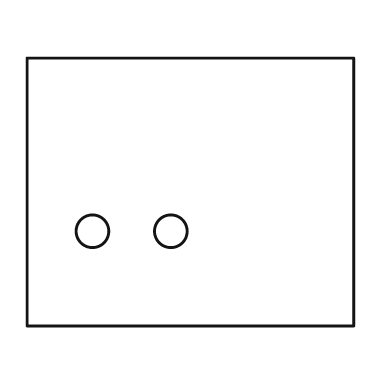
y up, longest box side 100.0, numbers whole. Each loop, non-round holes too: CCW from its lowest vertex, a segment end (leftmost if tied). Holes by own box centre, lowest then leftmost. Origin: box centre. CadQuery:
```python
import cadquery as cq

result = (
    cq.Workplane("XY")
    .moveTo(-50.0, -41.0)
    .lineTo(50.0, -41.0)
    .lineTo(50.0, 41.0)
    .lineTo(-50.0, 41.0)
    .close()
    .moveTo(-30.0, -12.0)
    .circle(5.0)
    .moveTo(-6.0, -12.0)
    .circle(5.0)
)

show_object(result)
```